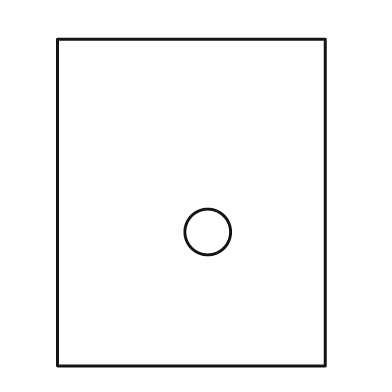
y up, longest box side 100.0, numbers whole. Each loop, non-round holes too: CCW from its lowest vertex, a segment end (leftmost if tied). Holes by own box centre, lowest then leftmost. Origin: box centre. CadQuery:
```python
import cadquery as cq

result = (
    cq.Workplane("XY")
    .moveTo(-41.0, -50.0)
    .lineTo(41.0, -50.0)
    .lineTo(41.0, 50.0)
    .lineTo(-41.0, 50.0)
    .close()
    .moveTo(5.0, -9.0)
    .circle(7.0)
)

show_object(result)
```